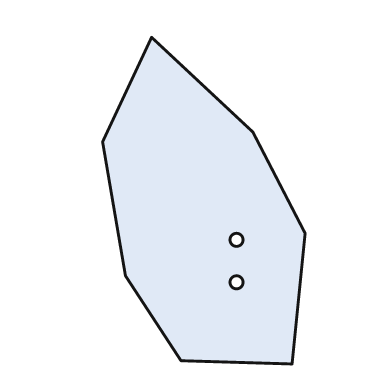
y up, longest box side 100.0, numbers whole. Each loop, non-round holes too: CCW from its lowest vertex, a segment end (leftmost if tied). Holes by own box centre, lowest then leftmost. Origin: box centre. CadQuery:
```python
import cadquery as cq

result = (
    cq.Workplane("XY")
    .moveTo(27.0, -50.0)
    .lineTo(31.0, -10.0)
    .lineTo(15.0, 21.0)
    .lineTo(-16.0, 50.0)
    .lineTo(-31.0, 18.0)
    .lineTo(-24.0, -23.0)
    .lineTo(-7.0, -49.0)
    .close()
    .moveTo(10.0, -25.0)
    .circle(2.0)
    .moveTo(10.0, -12.0)
    .circle(2.0)
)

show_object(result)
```